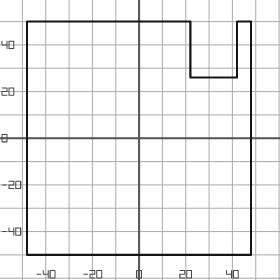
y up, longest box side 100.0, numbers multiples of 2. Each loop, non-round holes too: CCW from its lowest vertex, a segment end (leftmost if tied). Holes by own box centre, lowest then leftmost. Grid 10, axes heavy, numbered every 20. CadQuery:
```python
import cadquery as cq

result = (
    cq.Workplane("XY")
    .moveTo(-48.0, -50.0)
    .lineTo(48.0, -50.0)
    .lineTo(48.0, 50.0)
    .lineTo(42.0, 50.0)
    .lineTo(42.0, 26.0)
    .lineTo(22.0, 26.0)
    .lineTo(22.0, 50.0)
    .lineTo(-48.0, 50.0)
    .close()
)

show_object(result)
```